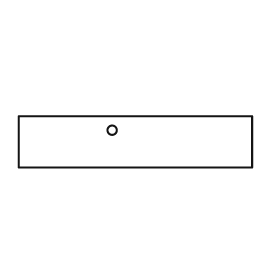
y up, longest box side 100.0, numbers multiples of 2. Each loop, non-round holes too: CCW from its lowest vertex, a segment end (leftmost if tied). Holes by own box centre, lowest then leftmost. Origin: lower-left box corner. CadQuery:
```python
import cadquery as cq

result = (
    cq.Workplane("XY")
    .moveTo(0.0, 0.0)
    .lineTo(100.0, 0.0)
    .lineTo(100.0, 22.0)
    .lineTo(0.0, 22.0)
    .close()
    .moveTo(40.0, 16.0)
    .circle(2.0)
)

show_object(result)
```